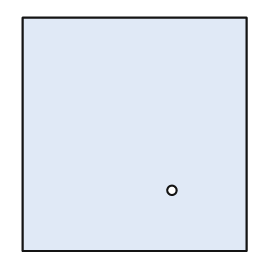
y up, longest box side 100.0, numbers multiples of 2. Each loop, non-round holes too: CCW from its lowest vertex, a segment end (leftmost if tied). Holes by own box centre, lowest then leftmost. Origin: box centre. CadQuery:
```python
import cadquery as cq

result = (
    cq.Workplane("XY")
    .moveTo(-48.0, -50.0)
    .lineTo(48.0, -50.0)
    .lineTo(48.0, 50.0)
    .lineTo(-48.0, 50.0)
    .close()
    .moveTo(16.0, -24.0)
    .circle(2.0)
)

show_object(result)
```